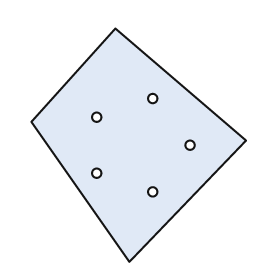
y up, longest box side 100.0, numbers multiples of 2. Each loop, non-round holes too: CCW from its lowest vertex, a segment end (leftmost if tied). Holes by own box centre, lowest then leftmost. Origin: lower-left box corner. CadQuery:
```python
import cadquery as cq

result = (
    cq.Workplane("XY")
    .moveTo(42.0, 0.0)
    .lineTo(92.0, 52.0)
    .lineTo(36.0, 100.0)
    .lineTo(0.0, 60.0)
    .close()
    .moveTo(52.0, 30.0)
    .circle(2.0)
    .moveTo(28.0, 38.0)
    .circle(2.0)
    .moveTo(68.0, 50.0)
    .circle(2.0)
    .moveTo(28.0, 62.0)
    .circle(2.0)
    .moveTo(52.0, 70.0)
    .circle(2.0)
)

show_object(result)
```